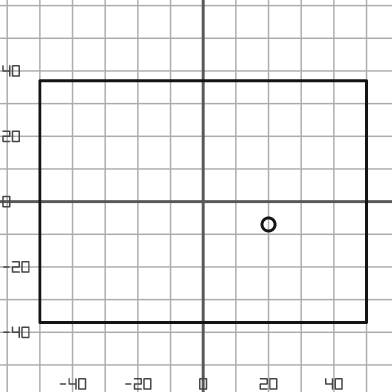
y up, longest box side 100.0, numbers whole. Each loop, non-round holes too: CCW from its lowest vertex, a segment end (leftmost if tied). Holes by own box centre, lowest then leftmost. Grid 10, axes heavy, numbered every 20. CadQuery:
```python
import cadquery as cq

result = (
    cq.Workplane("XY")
    .moveTo(-50.0, -37.0)
    .lineTo(50.0, -37.0)
    .lineTo(50.0, 37.0)
    .lineTo(-50.0, 37.0)
    .close()
    .moveTo(20.0, -7.0)
    .circle(2.0)
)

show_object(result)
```